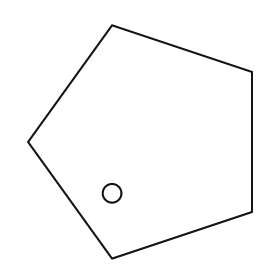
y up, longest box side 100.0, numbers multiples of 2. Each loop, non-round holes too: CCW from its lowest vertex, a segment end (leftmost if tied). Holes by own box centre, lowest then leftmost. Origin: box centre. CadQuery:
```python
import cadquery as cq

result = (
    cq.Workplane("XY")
    .moveTo(-12.0, -50.0)
    .lineTo(48.0, -30.0)
    .lineTo(48.0, 30.0)
    .lineTo(-12.0, 50.0)
    .lineTo(-48.0, 0.0)
    .close()
    .moveTo(-12.0, -22.0)
    .circle(4.0)
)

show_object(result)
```